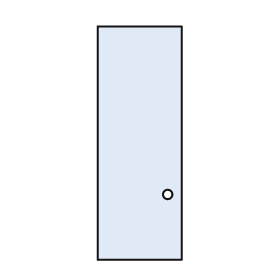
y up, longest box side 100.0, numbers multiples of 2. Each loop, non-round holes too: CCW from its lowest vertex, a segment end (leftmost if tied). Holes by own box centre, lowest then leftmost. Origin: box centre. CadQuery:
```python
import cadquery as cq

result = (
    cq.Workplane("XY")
    .moveTo(-18.0, -50.0)
    .lineTo(18.0, -50.0)
    .lineTo(18.0, 50.0)
    .lineTo(-18.0, 50.0)
    .close()
    .moveTo(12.0, -22.0)
    .circle(2.0)
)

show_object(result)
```